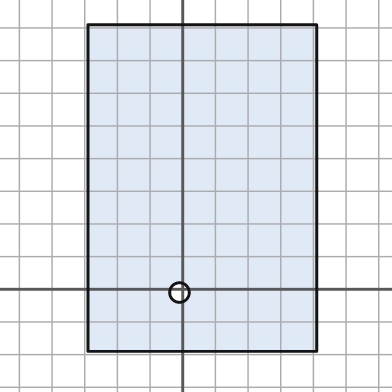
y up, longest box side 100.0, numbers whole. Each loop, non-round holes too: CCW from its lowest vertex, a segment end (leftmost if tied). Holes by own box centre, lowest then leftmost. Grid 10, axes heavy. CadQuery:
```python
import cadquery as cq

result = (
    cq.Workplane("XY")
    .moveTo(-29.0, -19.0)
    .lineTo(41.0, -19.0)
    .lineTo(41.0, 81.0)
    .lineTo(-29.0, 81.0)
    .close()
    .moveTo(-1.0, -1.0)
    .circle(3.0)
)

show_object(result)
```